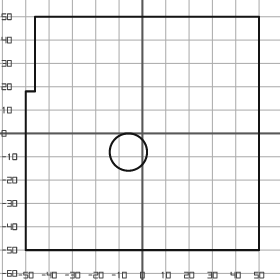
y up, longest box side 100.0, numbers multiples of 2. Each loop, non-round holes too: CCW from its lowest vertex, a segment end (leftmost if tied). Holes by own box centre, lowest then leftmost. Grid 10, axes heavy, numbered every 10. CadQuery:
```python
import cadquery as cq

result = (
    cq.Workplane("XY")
    .moveTo(-50.0, -50.0)
    .lineTo(50.0, -50.0)
    .lineTo(50.0, 50.0)
    .lineTo(-46.0, 50.0)
    .lineTo(-46.0, 18.0)
    .lineTo(-50.0, 18.0)
    .close()
    .moveTo(-6.0, -8.0)
    .circle(8.0)
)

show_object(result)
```